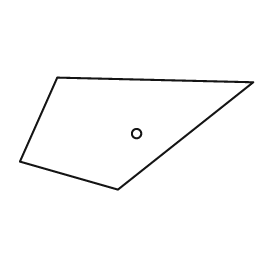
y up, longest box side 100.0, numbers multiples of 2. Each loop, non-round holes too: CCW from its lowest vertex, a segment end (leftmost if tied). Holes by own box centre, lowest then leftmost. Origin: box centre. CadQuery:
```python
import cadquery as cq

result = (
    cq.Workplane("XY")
    .moveTo(-8.0, -24.0)
    .lineTo(50.0, 22.0)
    .lineTo(-34.0, 24.0)
    .lineTo(-50.0, -12.0)
    .close()
    .moveTo(0.0, 0.0)
    .circle(2.0)
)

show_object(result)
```